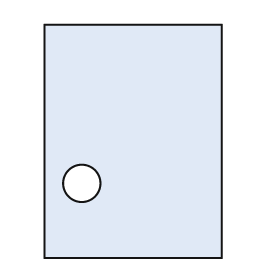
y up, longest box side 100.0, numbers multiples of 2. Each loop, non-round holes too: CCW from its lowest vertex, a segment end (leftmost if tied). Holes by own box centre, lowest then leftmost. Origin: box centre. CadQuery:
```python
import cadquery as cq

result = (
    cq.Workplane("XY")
    .moveTo(-38.0, -50.0)
    .lineTo(38.0, -50.0)
    .lineTo(38.0, 50.0)
    .lineTo(-38.0, 50.0)
    .close()
    .moveTo(-22.0, -18.0)
    .circle(8.0)
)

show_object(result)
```